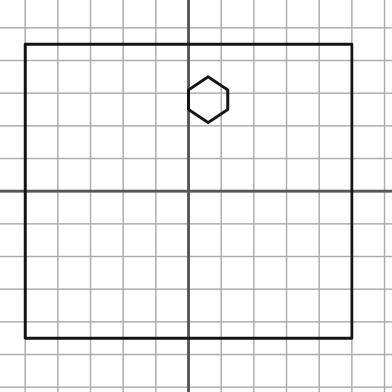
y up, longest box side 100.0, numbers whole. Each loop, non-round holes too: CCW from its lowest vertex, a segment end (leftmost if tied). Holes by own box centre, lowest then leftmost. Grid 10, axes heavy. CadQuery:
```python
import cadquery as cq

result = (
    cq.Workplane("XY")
    .moveTo(-50.0, -45.0)
    .lineTo(50.0, -45.0)
    .lineTo(50.0, 45.0)
    .lineTo(-50.0, 45.0)
    .close()
    .moveTo(6.0, 21.0)
    .lineTo(12.0, 25.0)
    .lineTo(12.0, 31.0)
    .lineTo(6.0, 35.0)
    .lineTo(0.0, 31.0)
    .lineTo(0.0, 25.0)
    .close()
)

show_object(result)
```